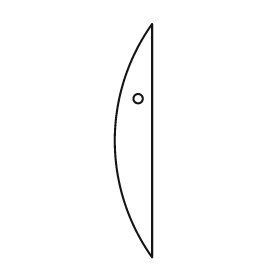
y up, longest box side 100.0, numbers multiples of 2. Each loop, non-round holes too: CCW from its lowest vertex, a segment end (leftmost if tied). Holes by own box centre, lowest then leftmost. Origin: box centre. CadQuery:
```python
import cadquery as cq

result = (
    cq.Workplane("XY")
    .moveTo(8.0, -50.0)
    .lineTo(8.0, 50.0)
    .threePointArc((-8.0, 0.0), (8.0, -50.0))
    .close()
    .moveTo(2.0, 18.0)
    .circle(2.0)
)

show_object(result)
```